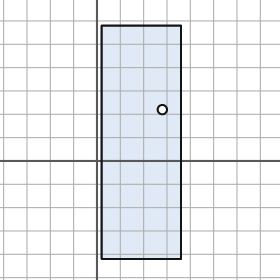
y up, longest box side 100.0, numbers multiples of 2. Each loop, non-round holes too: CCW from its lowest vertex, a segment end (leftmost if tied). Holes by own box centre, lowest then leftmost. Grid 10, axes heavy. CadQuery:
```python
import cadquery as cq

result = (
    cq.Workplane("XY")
    .moveTo(2.0, -42.0)
    .lineTo(36.0, -42.0)
    .lineTo(36.0, 58.0)
    .lineTo(2.0, 58.0)
    .close()
    .moveTo(28.0, 22.0)
    .circle(2.0)
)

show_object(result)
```